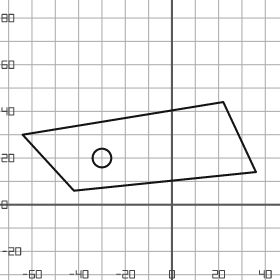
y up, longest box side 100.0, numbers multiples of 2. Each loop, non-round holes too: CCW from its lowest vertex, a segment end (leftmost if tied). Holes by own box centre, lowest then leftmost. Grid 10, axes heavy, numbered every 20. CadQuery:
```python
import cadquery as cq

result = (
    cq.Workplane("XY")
    .moveTo(-42.0, 6.0)
    .lineTo(36.0, 14.0)
    .lineTo(22.0, 44.0)
    .lineTo(-64.0, 30.0)
    .close()
    .moveTo(-30.0, 20.0)
    .circle(4.0)
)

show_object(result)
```